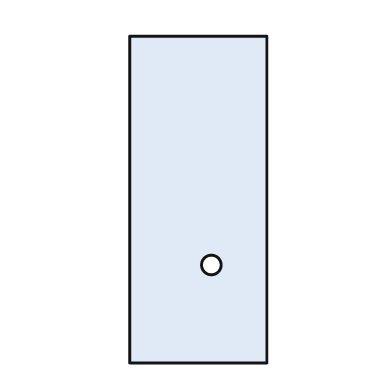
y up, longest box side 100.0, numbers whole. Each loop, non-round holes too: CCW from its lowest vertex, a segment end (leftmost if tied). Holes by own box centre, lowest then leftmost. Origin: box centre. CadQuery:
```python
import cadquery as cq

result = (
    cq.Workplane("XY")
    .moveTo(-21.0, -50.0)
    .lineTo(21.0, -50.0)
    .lineTo(21.0, 50.0)
    .lineTo(-21.0, 50.0)
    .close()
    .moveTo(4.0, -20.0)
    .circle(3.0)
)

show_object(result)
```